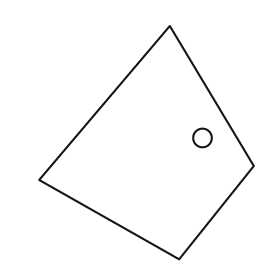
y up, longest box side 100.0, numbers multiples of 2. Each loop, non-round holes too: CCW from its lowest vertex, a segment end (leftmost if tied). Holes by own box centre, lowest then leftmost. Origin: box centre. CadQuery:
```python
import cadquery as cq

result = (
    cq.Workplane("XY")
    .moveTo(14.0, -50.0)
    .lineTo(46.0, -10.0)
    .lineTo(10.0, 50.0)
    .lineTo(-46.0, -16.0)
    .close()
    .moveTo(24.0, 2.0)
    .circle(4.0)
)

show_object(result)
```